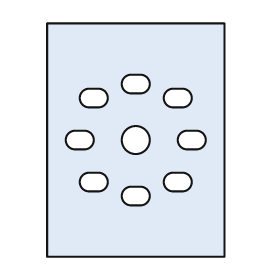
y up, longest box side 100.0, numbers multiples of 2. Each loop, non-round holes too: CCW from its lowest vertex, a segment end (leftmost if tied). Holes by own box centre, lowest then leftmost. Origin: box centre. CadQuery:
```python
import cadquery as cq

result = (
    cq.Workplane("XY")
    .moveTo(-38.0, -50.0)
    .lineTo(38.0, -50.0)
    .lineTo(38.0, 50.0)
    .lineTo(-38.0, 50.0)
    .close()
    .moveTo(-2.0, -28.0)
    .lineTo(2.0, -28.0)
    .threePointArc((6.0, -24.0), (2.0, -20.0))
    .lineTo(-2.0, -20.0)
    .threePointArc((-6.0, -24.0), (-2.0, -28.0))
    .close()
    .moveTo(-20.0, -22.0)
    .lineTo(-16.0, -22.0)
    .threePointArc((-12.0, -18.0), (-16.0, -14.0))
    .lineTo(-20.0, -14.0)
    .threePointArc((-24.0, -18.0), (-20.0, -22.0))
    .close()
    .moveTo(16.0, -22.0)
    .lineTo(20.0, -22.0)
    .threePointArc((24.0, -18.0), (20.0, -14.0))
    .lineTo(16.0, -14.0)
    .threePointArc((12.0, -18.0), (16.0, -22.0))
    .close()
    .moveTo(-26.0, -4.0)
    .lineTo(-22.0, -4.0)
    .threePointArc((-18.0, 0.0), (-22.0, 4.0))
    .lineTo(-26.0, 4.0)
    .threePointArc((-30.0, 0.0), (-26.0, -4.0))
    .close()
    .moveTo(0.0, 0.0)
    .circle(6.0)
    .moveTo(22.0, -4.0)
    .lineTo(26.0, -4.0)
    .threePointArc((30.0, 0.0), (26.0, 4.0))
    .lineTo(22.0, 4.0)
    .threePointArc((18.0, 0.0), (22.0, -4.0))
    .close()
    .moveTo(-20.0, 14.0)
    .lineTo(-16.0, 14.0)
    .threePointArc((-12.0, 18.0), (-16.0, 22.0))
    .lineTo(-20.0, 22.0)
    .threePointArc((-24.0, 18.0), (-20.0, 14.0))
    .close()
    .moveTo(16.0, 14.0)
    .lineTo(20.0, 14.0)
    .threePointArc((24.0, 18.0), (20.0, 22.0))
    .lineTo(16.0, 22.0)
    .threePointArc((12.0, 18.0), (16.0, 14.0))
    .close()
    .moveTo(-2.0, 20.0)
    .lineTo(2.0, 20.0)
    .threePointArc((6.0, 24.0), (2.0, 28.0))
    .lineTo(-2.0, 28.0)
    .threePointArc((-6.0, 24.0), (-2.0, 20.0))
    .close()
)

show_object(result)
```